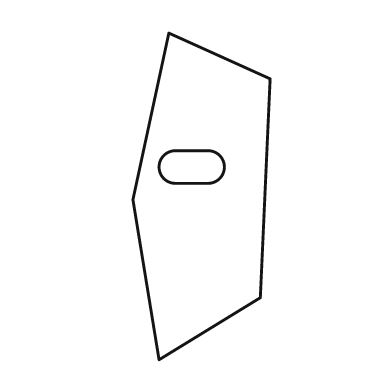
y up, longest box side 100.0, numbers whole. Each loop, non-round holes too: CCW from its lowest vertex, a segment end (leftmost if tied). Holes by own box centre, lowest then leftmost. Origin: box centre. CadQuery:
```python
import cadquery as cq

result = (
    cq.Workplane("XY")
    .moveTo(-13.0, -50.0)
    .lineTo(18.0, -31.0)
    .lineTo(21.0, 36.0)
    .lineTo(-10.0, 50.0)
    .lineTo(-21.0, -1.0)
    .close()
    .moveTo(-8.0, 4.0)
    .lineTo(2.0, 4.0)
    .threePointArc((7.0, 9.0), (2.0, 14.0))
    .lineTo(-8.0, 14.0)
    .threePointArc((-13.0, 9.0), (-8.0, 4.0))
    .close()
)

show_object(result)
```